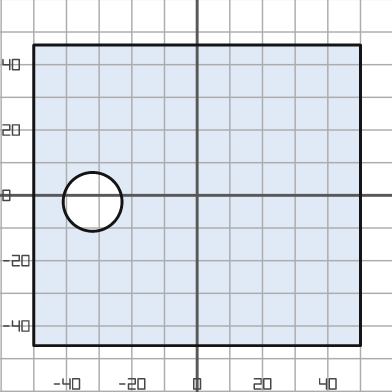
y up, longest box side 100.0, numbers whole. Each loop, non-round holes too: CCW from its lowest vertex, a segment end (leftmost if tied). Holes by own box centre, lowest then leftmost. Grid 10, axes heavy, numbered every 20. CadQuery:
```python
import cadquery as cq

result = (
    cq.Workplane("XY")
    .moveTo(-50.0, -46.0)
    .lineTo(50.0, -46.0)
    .lineTo(50.0, 46.0)
    .lineTo(-50.0, 46.0)
    .close()
    .moveTo(-32.0, -2.0)
    .circle(9.0)
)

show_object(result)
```